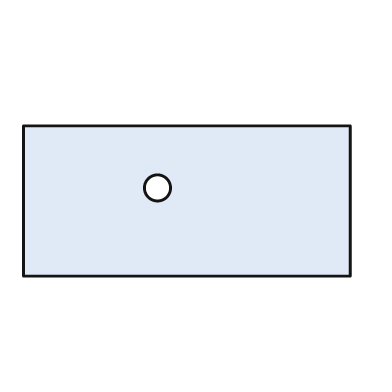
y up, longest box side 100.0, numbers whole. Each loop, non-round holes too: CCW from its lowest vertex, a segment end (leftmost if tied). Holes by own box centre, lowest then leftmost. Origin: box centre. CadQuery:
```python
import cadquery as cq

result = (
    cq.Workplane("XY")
    .moveTo(-50.0, -23.0)
    .lineTo(50.0, -23.0)
    .lineTo(50.0, 23.0)
    .lineTo(-50.0, 23.0)
    .close()
    .moveTo(-9.0, 4.0)
    .circle(4.0)
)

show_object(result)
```